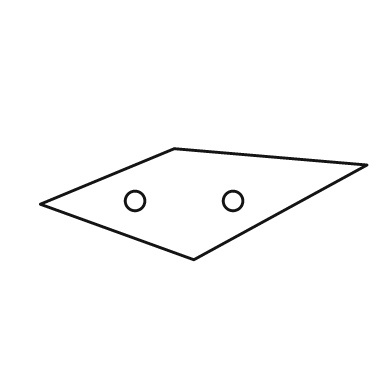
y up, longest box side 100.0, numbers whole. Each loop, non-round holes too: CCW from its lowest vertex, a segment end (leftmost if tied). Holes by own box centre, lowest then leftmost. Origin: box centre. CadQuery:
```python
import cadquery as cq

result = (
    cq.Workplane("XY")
    .moveTo(-3.0, -17.0)
    .lineTo(50.0, 12.0)
    .lineTo(-9.0, 17.0)
    .lineTo(-50.0, 0.0)
    .close()
    .moveTo(-21.0, 1.0)
    .circle(3.0)
    .moveTo(9.0, 1.0)
    .circle(3.0)
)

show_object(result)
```